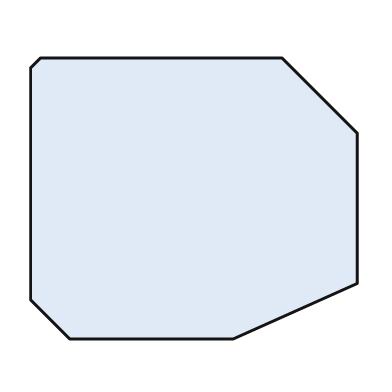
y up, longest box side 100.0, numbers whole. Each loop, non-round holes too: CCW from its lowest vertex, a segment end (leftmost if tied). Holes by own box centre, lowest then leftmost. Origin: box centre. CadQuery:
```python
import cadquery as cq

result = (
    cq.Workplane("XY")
    .moveTo(-38.0, -43.0)
    .lineTo(12.0, -43.0)
    .lineTo(50.0, -26.0)
    .lineTo(50.0, 20.0)
    .lineTo(27.0, 43.0)
    .lineTo(-47.0, 43.0)
    .lineTo(-50.0, 40.0)
    .lineTo(-50.0, -31.0)
    .close()
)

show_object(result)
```